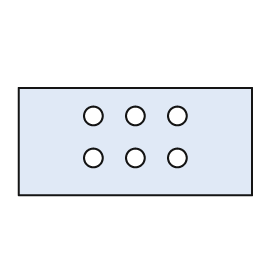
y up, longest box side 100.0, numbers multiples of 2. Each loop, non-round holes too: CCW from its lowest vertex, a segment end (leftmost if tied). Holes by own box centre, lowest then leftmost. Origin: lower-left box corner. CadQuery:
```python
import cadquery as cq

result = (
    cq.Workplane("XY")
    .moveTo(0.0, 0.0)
    .lineTo(100.0, 0.0)
    .lineTo(100.0, 46.0)
    .lineTo(0.0, 46.0)
    .close()
    .moveTo(32.0, 16.0)
    .circle(4.0)
    .moveTo(50.0, 16.0)
    .circle(4.0)
    .moveTo(68.0, 16.0)
    .circle(4.0)
    .moveTo(32.0, 34.0)
    .circle(4.0)
    .moveTo(50.0, 34.0)
    .circle(4.0)
    .moveTo(68.0, 34.0)
    .circle(4.0)
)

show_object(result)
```